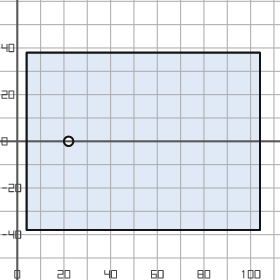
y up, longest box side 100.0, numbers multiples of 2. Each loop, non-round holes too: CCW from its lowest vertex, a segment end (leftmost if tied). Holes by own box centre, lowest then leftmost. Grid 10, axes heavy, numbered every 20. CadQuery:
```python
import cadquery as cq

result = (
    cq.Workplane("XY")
    .moveTo(4.0, -38.0)
    .lineTo(104.0, -38.0)
    .lineTo(104.0, 38.0)
    .lineTo(4.0, 38.0)
    .close()
    .moveTo(22.0, 0.0)
    .circle(2.0)
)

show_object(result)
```